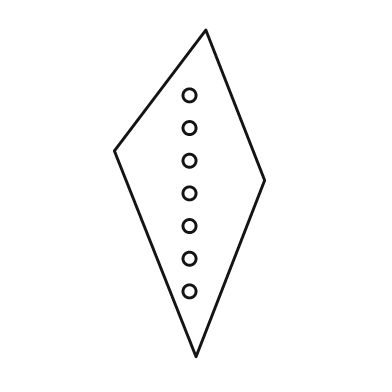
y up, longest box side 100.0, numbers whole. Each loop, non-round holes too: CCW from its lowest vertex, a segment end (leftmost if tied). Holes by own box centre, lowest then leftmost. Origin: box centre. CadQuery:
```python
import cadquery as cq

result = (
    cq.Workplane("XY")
    .moveTo(2.0, -50.0)
    .lineTo(23.0, 4.0)
    .lineTo(5.0, 50.0)
    .lineTo(-23.0, 13.0)
    .close()
    .moveTo(0.0, -30.0)
    .circle(2.0)
    .moveTo(0.0, -20.0)
    .circle(2.0)
    .moveTo(0.0, -10.0)
    .circle(2.0)
    .moveTo(0.0, 0.0)
    .circle(2.0)
    .moveTo(0.0, 10.0)
    .circle(2.0)
    .moveTo(0.0, 20.0)
    .circle(2.0)
    .moveTo(0.0, 30.0)
    .circle(2.0)
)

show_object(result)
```